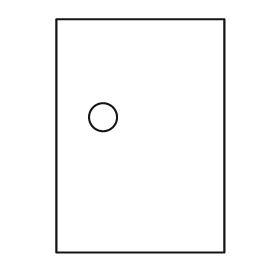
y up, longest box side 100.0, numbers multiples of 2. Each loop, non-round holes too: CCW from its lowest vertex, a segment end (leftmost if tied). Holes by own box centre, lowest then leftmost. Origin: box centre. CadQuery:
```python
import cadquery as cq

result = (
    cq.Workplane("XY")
    .moveTo(-36.0, -50.0)
    .lineTo(36.0, -50.0)
    .lineTo(36.0, 50.0)
    .lineTo(-36.0, 50.0)
    .close()
    .moveTo(-16.0, 8.0)
    .circle(6.0)
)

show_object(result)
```